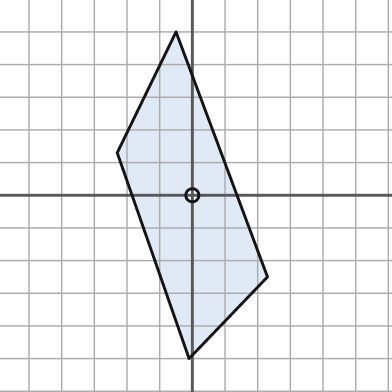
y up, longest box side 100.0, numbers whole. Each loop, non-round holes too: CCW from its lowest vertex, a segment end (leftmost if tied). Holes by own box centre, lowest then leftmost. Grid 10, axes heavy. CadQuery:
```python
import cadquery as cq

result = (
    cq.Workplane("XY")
    .moveTo(-1.0, -50.0)
    .lineTo(23.0, -25.0)
    .lineTo(-5.0, 50.0)
    .lineTo(-23.0, 13.0)
    .close()
    .moveTo(0.0, 0.0)
    .circle(2.0)
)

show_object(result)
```